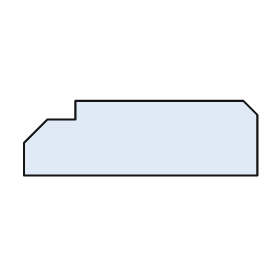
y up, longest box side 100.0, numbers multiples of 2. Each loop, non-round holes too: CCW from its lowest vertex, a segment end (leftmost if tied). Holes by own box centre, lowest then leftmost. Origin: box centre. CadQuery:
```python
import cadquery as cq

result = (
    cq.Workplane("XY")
    .moveTo(-50.0, -16.0)
    .lineTo(50.0, -16.0)
    .lineTo(50.0, 10.0)
    .lineTo(44.0, 16.0)
    .lineTo(-28.0, 16.0)
    .lineTo(-28.0, 8.0)
    .lineTo(-40.0, 8.0)
    .lineTo(-50.0, -2.0)
    .close()
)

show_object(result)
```